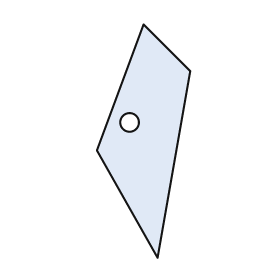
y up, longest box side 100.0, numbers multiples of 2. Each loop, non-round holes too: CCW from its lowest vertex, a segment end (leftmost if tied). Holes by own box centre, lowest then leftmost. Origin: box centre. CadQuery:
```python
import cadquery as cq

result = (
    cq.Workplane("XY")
    .moveTo(6.0, -50.0)
    .lineTo(20.0, 30.0)
    .lineTo(0.0, 50.0)
    .lineTo(-20.0, -4.0)
    .close()
    .moveTo(-6.0, 8.0)
    .circle(4.0)
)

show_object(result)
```